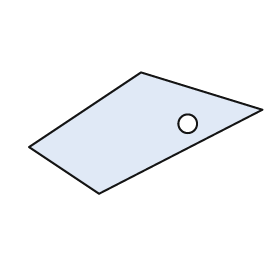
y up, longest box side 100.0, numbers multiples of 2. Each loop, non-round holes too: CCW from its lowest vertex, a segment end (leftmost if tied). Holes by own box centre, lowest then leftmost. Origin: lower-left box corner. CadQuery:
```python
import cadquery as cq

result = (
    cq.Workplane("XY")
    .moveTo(30.0, 0.0)
    .lineTo(100.0, 36.0)
    .lineTo(48.0, 52.0)
    .lineTo(0.0, 20.0)
    .close()
    .moveTo(68.0, 30.0)
    .circle(4.0)
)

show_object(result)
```